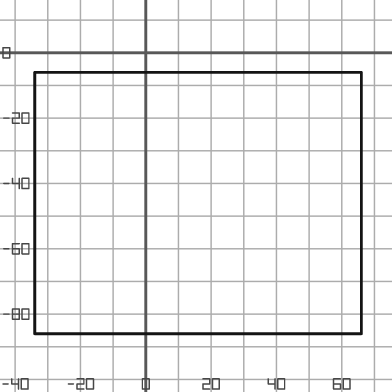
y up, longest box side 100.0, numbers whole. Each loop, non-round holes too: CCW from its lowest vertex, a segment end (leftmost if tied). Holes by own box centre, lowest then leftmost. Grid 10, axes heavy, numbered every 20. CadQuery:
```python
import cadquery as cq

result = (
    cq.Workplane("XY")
    .moveTo(-34.0, -86.0)
    .lineTo(66.0, -86.0)
    .lineTo(66.0, -6.0)
    .lineTo(-34.0, -6.0)
    .close()
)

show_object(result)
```